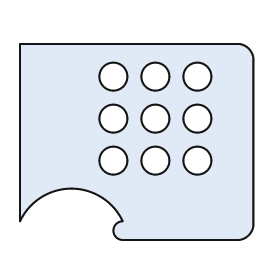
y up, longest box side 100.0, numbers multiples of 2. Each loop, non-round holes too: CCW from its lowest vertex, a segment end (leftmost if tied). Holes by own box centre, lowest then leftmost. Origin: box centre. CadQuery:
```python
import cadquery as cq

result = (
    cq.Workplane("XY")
    .moveTo(-6.0, -42.0)
    .lineTo(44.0, -42.0)
    .threePointArc((48.0, -40.0), (50.0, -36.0))
    .lineTo(50.0, 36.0)
    .threePointArc((48.0, 40.0), (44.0, 42.0))
    .lineTo(-50.0, 42.0)
    .lineTo(-50.0, -34.0)
    .threePointArc((-28.0, -20.0), (-6.0, -34.0))
    .threePointArc((-10.0, -38.0), (-6.0, -42.0))
    .close()
    .moveTo(-10.0, -8.0)
    .circle(6.0)
    .moveTo(8.0, -8.0)
    .circle(6.0)
    .moveTo(26.0, -8.0)
    .circle(6.0)
    .moveTo(-10.0, 10.0)
    .circle(6.0)
    .moveTo(8.0, 10.0)
    .circle(6.0)
    .moveTo(26.0, 10.0)
    .circle(6.0)
    .moveTo(-10.0, 28.0)
    .circle(6.0)
    .moveTo(8.0, 28.0)
    .circle(6.0)
    .moveTo(26.0, 28.0)
    .circle(6.0)
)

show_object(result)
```